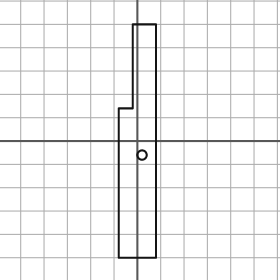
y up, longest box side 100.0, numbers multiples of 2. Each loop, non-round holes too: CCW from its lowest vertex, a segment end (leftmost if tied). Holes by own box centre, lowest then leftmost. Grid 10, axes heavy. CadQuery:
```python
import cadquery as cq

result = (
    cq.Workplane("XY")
    .moveTo(-8.0, -50.0)
    .lineTo(8.0, -50.0)
    .lineTo(8.0, 50.0)
    .lineTo(-2.0, 50.0)
    .lineTo(-2.0, 14.0)
    .lineTo(-8.0, 14.0)
    .close()
    .moveTo(2.0, -6.0)
    .circle(2.0)
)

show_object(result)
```